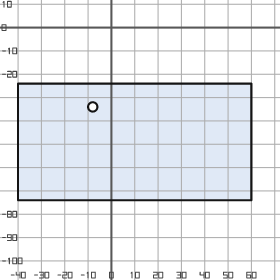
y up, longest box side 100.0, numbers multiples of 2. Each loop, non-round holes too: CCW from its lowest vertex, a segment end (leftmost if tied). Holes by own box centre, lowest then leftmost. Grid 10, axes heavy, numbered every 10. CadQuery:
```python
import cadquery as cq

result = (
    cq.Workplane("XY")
    .moveTo(-40.0, -74.0)
    .lineTo(60.0, -74.0)
    .lineTo(60.0, -24.0)
    .lineTo(-40.0, -24.0)
    .close()
    .moveTo(-8.0, -34.0)
    .circle(2.0)
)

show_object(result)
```